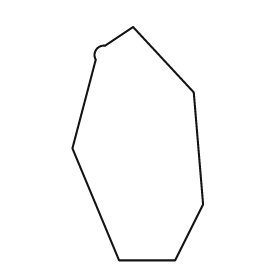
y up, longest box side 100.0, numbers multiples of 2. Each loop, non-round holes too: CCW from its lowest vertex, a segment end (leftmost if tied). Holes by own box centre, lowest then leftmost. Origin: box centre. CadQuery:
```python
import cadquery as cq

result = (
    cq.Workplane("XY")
    .moveTo(-8.0, -50.0)
    .lineTo(16.0, -50.0)
    .lineTo(28.0, -26.0)
    .lineTo(24.0, 22.0)
    .lineTo(-2.0, 50.0)
    .lineTo(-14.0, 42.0)
    .threePointArc((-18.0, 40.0), (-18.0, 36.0))
    .lineTo(-28.0, -2.0)
    .close()
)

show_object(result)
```